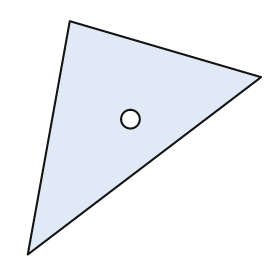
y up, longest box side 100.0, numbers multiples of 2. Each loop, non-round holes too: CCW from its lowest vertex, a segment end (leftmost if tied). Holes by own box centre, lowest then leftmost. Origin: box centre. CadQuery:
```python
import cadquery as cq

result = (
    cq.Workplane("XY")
    .moveTo(-50.0, -50.0)
    .lineTo(50.0, 26.0)
    .lineTo(-32.0, 50.0)
    .close()
    .moveTo(-6.0, 8.0)
    .circle(4.0)
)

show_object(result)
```